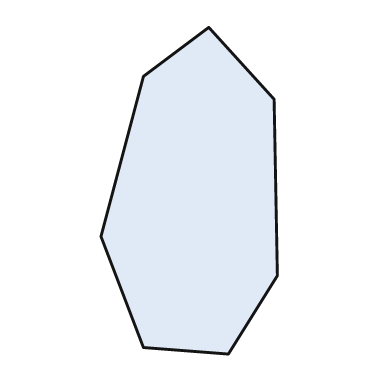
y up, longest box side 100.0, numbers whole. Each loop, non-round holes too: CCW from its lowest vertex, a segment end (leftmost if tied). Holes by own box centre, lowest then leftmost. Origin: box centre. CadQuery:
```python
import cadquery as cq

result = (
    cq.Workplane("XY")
    .moveTo(12.0, -50.0)
    .lineTo(27.0, -26.0)
    .lineTo(26.0, 28.0)
    .lineTo(6.0, 50.0)
    .lineTo(-14.0, 35.0)
    .lineTo(-27.0, -14.0)
    .lineTo(-14.0, -48.0)
    .close()
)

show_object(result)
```